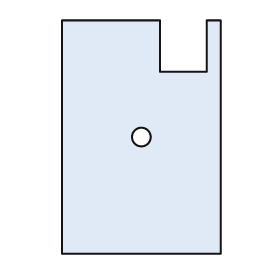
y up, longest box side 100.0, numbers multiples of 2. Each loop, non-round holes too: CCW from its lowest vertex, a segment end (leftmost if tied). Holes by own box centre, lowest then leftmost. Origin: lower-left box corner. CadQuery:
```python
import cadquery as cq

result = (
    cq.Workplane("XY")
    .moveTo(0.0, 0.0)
    .lineTo(68.0, 0.0)
    .lineTo(68.0, 100.0)
    .lineTo(62.0, 100.0)
    .lineTo(62.0, 78.0)
    .lineTo(42.0, 78.0)
    .lineTo(42.0, 100.0)
    .lineTo(0.0, 100.0)
    .close()
    .moveTo(34.0, 50.0)
    .circle(4.0)
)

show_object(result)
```